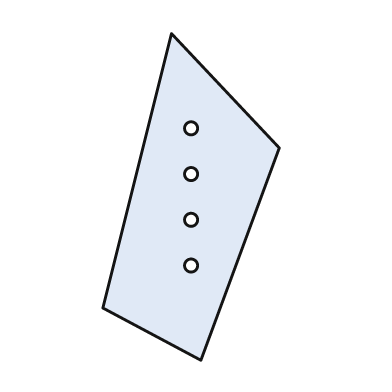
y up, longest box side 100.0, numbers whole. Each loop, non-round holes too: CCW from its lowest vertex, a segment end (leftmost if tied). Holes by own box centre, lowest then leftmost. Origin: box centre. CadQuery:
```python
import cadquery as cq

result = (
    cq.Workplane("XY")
    .moveTo(3.0, -50.0)
    .lineTo(27.0, 15.0)
    .lineTo(-6.0, 50.0)
    .lineTo(-27.0, -34.0)
    .close()
    .moveTo(0.0, -21.0)
    .circle(2.0)
    .moveTo(0.0, -7.0)
    .circle(2.0)
    .moveTo(0.0, 7.0)
    .circle(2.0)
    .moveTo(0.0, 21.0)
    .circle(2.0)
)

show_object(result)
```